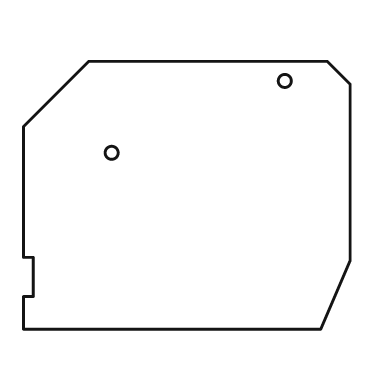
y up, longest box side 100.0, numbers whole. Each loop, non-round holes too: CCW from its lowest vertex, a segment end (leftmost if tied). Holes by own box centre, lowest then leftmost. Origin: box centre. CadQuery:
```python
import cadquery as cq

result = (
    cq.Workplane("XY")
    .moveTo(-50.0, -41.0)
    .lineTo(41.0, -41.0)
    .lineTo(50.0, -20.0)
    .lineTo(50.0, 34.0)
    .lineTo(43.0, 41.0)
    .lineTo(-30.0, 41.0)
    .lineTo(-50.0, 21.0)
    .lineTo(-50.0, -19.0)
    .lineTo(-47.0, -19.0)
    .lineTo(-47.0, -31.0)
    .lineTo(-50.0, -31.0)
    .close()
    .moveTo(-23.0, 13.0)
    .circle(2.0)
    .moveTo(30.0, 35.0)
    .circle(2.0)
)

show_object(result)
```